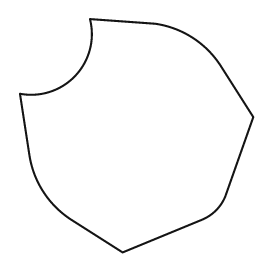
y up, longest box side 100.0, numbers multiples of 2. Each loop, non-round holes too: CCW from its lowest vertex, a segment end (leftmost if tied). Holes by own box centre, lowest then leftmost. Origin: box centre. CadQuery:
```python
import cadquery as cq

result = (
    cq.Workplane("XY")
    .moveTo(-6.0, -50.0)
    .lineTo(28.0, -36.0)
    .threePointArc((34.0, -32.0), (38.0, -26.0))
    .lineTo(50.0, 8.0)
    .lineTo(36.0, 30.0)
    .threePointArc((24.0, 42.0), (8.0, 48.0))
    .lineTo(-20.0, 50.0)
    .threePointArc((-26.0, 26.0), (-50.0, 18.0))
    .lineTo(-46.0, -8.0)
    .threePointArc((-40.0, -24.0), (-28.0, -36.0))
    .close()
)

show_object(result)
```